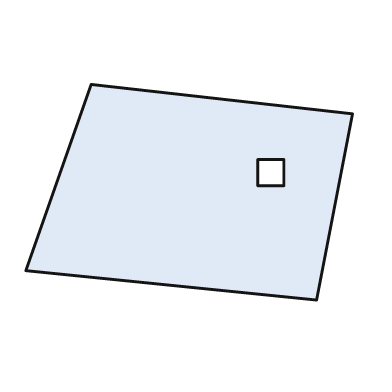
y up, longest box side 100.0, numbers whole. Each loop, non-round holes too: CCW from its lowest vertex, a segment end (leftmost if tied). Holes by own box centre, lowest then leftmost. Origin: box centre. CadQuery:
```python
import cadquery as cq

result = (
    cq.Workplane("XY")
    .moveTo(39.0, -33.0)
    .lineTo(50.0, 24.0)
    .lineTo(-30.0, 33.0)
    .lineTo(-50.0, -24.0)
    .close()
    .moveTo(21.0, 2.0)
    .lineTo(29.0, 2.0)
    .lineTo(29.0, 10.0)
    .lineTo(21.0, 10.0)
    .close()
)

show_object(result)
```